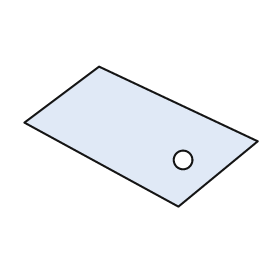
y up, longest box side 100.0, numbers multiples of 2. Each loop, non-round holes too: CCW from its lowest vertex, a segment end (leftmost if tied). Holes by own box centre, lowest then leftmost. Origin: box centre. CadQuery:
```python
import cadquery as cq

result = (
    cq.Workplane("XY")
    .moveTo(16.0, -30.0)
    .lineTo(50.0, -2.0)
    .lineTo(-18.0, 30.0)
    .lineTo(-50.0, 6.0)
    .close()
    .moveTo(18.0, -10.0)
    .circle(4.0)
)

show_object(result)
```